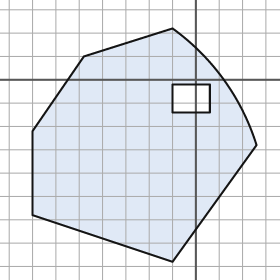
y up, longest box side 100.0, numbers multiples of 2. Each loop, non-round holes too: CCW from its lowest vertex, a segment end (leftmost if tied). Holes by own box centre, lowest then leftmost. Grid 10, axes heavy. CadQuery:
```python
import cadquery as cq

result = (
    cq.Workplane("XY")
    .moveTo(-10.0, -78.0)
    .lineTo(26.0, -28.0)
    .threePointArc((12.0, 0.0), (-10.0, 22.0))
    .lineTo(-48.0, 10.0)
    .lineTo(-70.0, -22.0)
    .lineTo(-70.0, -58.0)
    .close()
    .moveTo(-10.0, -14.0)
    .lineTo(6.0, -14.0)
    .lineTo(6.0, -2.0)
    .lineTo(-10.0, -2.0)
    .close()
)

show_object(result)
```